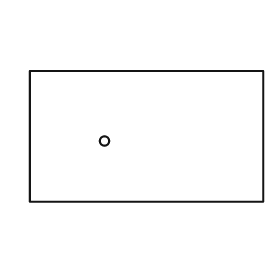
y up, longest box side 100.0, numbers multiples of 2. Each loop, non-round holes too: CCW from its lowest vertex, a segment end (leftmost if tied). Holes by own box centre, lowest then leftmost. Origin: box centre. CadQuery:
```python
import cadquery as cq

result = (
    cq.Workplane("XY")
    .moveTo(-50.0, -28.0)
    .lineTo(50.0, -28.0)
    .lineTo(50.0, 28.0)
    .lineTo(-50.0, 28.0)
    .close()
    .moveTo(-18.0, -2.0)
    .circle(2.0)
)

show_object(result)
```